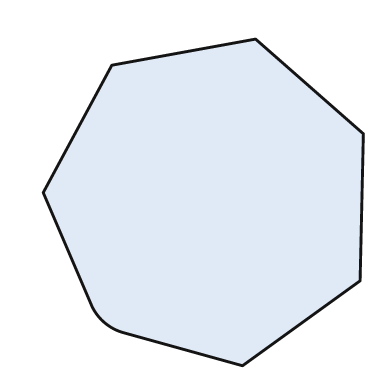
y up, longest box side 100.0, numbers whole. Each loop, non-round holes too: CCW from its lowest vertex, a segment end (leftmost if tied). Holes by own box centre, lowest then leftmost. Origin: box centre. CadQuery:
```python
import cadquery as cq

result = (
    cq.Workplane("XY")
    .moveTo(12.0, -50.0)
    .lineTo(48.0, -24.0)
    .lineTo(49.0, 21.0)
    .lineTo(16.0, 50.0)
    .lineTo(-28.0, 42.0)
    .lineTo(-49.0, 3.0)
    .lineTo(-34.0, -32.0)
    .threePointArc((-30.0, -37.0), (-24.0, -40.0))
    .close()
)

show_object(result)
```